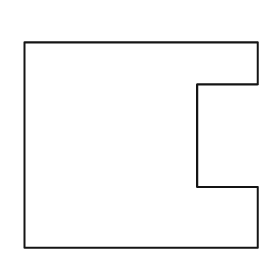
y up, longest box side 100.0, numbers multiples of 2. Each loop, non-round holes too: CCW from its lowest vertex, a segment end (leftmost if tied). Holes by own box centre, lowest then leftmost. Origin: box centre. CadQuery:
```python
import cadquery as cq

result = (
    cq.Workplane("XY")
    .moveTo(-50.0, -44.0)
    .lineTo(50.0, -44.0)
    .lineTo(50.0, -18.0)
    .lineTo(24.0, -18.0)
    .lineTo(24.0, 26.0)
    .lineTo(50.0, 26.0)
    .lineTo(50.0, 44.0)
    .lineTo(-50.0, 44.0)
    .close()
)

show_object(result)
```